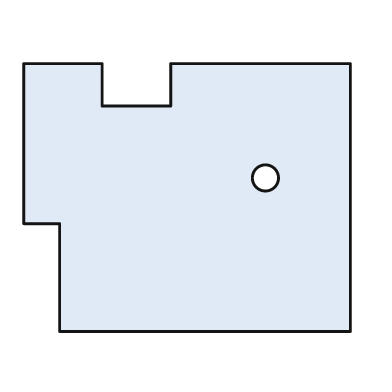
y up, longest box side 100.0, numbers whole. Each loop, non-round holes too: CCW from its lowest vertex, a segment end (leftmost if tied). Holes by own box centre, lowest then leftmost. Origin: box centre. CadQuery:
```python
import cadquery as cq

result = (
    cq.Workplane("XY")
    .moveTo(-39.0, -41.0)
    .lineTo(50.0, -41.0)
    .lineTo(50.0, 41.0)
    .lineTo(-5.0, 41.0)
    .lineTo(-5.0, 28.0)
    .lineTo(-26.0, 28.0)
    .lineTo(-26.0, 41.0)
    .lineTo(-50.0, 41.0)
    .lineTo(-50.0, -8.0)
    .lineTo(-39.0, -8.0)
    .close()
    .moveTo(24.0, 6.0)
    .circle(4.0)
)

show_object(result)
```